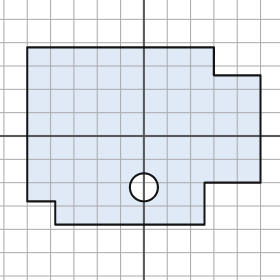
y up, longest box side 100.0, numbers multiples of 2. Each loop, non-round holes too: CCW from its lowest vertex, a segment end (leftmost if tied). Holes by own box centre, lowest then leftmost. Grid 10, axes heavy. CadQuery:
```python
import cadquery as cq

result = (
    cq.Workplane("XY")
    .moveTo(-38.0, -38.0)
    .lineTo(26.0, -38.0)
    .lineTo(26.0, -20.0)
    .lineTo(50.0, -20.0)
    .lineTo(50.0, 26.0)
    .lineTo(30.0, 26.0)
    .lineTo(30.0, 38.0)
    .lineTo(-50.0, 38.0)
    .lineTo(-50.0, -28.0)
    .lineTo(-38.0, -28.0)
    .close()
    .moveTo(0.0, -22.0)
    .circle(6.0)
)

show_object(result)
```